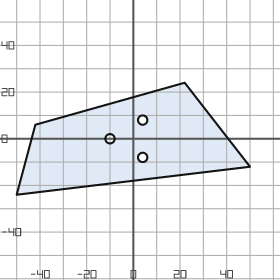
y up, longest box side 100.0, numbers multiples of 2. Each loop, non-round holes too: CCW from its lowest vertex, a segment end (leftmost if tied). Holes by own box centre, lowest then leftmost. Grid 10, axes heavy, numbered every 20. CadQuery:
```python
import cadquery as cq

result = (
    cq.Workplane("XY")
    .moveTo(-50.0, -24.0)
    .lineTo(50.0, -12.0)
    .lineTo(22.0, 24.0)
    .lineTo(-42.0, 6.0)
    .close()
    .moveTo(4.0, -8.0)
    .circle(2.0)
    .moveTo(-10.0, 0.0)
    .circle(2.0)
    .moveTo(4.0, 8.0)
    .circle(2.0)
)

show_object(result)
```